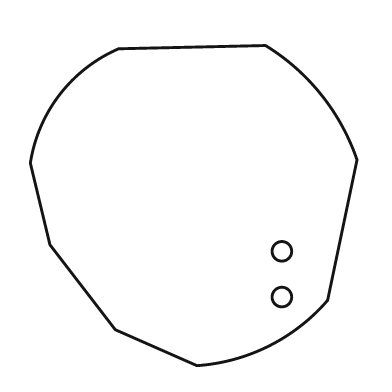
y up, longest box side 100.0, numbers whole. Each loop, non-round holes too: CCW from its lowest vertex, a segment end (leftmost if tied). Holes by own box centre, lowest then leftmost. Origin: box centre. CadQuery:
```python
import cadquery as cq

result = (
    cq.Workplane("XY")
    .moveTo(1.0, -49.0)
    .threePointArc((23.0, -43.0), (41.0, -29.0))
    .lineTo(50.0, 14.0)
    .threePointArc((39.0, 34.0), (22.0, 49.0))
    .lineTo(-23.0, 48.0)
    .threePointArc((-41.0, 34.0), (-50.0, 13.0))
    .lineTo(-44.0, -12.0)
    .lineTo(-24.0, -38.0)
    .close()
    .moveTo(27.0, -28.0)
    .circle(3.0)
    .moveTo(27.0, -14.0)
    .circle(3.0)
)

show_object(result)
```